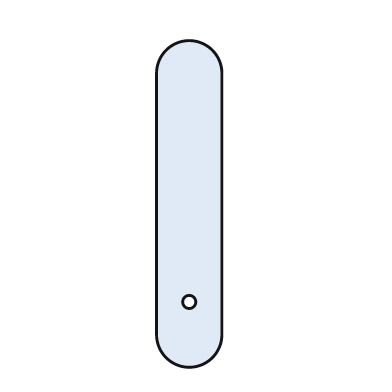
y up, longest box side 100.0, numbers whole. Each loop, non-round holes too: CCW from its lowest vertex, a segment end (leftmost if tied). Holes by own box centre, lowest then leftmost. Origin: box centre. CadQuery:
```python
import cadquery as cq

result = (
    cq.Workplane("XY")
    .moveTo(-10.0, -40.0)
    .threePointArc((0.0, -50.0), (10.0, -40.0))
    .lineTo(10.0, 40.0)
    .threePointArc((0.0, 50.0), (-10.0, 40.0))
    .close()
    .moveTo(0.0, -30.0)
    .circle(2.0)
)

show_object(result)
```